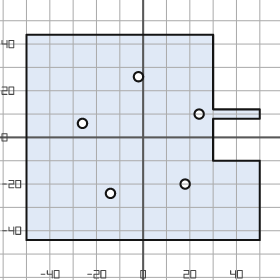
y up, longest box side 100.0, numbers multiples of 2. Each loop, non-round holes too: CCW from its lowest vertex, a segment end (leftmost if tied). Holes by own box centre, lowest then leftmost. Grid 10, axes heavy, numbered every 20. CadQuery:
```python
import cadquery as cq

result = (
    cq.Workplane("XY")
    .moveTo(-50.0, -44.0)
    .lineTo(50.0, -44.0)
    .lineTo(50.0, -10.0)
    .lineTo(30.0, -10.0)
    .lineTo(30.0, 8.0)
    .lineTo(50.0, 8.0)
    .lineTo(50.0, 12.0)
    .lineTo(30.0, 12.0)
    .lineTo(30.0, 44.0)
    .lineTo(-50.0, 44.0)
    .close()
    .moveTo(-14.0, -24.0)
    .circle(2.0)
    .moveTo(18.0, -20.0)
    .circle(2.0)
    .moveTo(-26.0, 6.0)
    .circle(2.0)
    .moveTo(24.0, 10.0)
    .circle(2.0)
    .moveTo(-2.0, 26.0)
    .circle(2.0)
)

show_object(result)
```